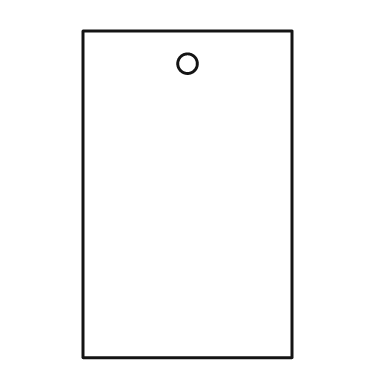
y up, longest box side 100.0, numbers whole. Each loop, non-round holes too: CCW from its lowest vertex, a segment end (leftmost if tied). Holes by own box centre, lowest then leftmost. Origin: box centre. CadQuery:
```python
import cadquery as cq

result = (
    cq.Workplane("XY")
    .moveTo(-32.0, -50.0)
    .lineTo(32.0, -50.0)
    .lineTo(32.0, 50.0)
    .lineTo(-32.0, 50.0)
    .close()
    .moveTo(0.0, 40.0)
    .circle(3.0)
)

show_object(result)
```